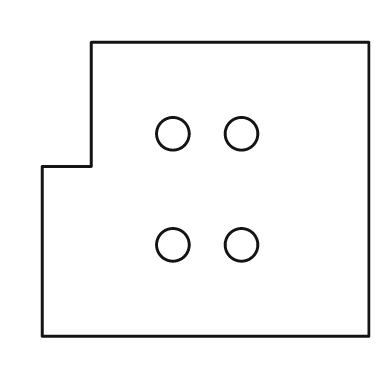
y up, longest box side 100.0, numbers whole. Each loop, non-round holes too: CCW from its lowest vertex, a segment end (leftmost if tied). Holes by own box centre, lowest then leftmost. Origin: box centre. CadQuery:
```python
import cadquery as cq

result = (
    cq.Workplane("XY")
    .moveTo(-50.0, -45.0)
    .lineTo(50.0, -45.0)
    .lineTo(50.0, 45.0)
    .lineTo(-35.0, 45.0)
    .lineTo(-35.0, 7.0)
    .lineTo(-50.0, 7.0)
    .close()
    .moveTo(-10.0, -17.0)
    .circle(5.0)
    .moveTo(11.0, -17.0)
    .circle(5.0)
    .moveTo(-10.0, 17.0)
    .circle(5.0)
    .moveTo(11.0, 17.0)
    .circle(5.0)
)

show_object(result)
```